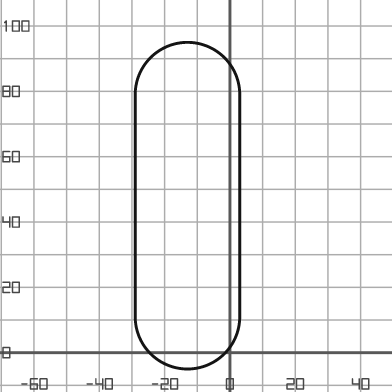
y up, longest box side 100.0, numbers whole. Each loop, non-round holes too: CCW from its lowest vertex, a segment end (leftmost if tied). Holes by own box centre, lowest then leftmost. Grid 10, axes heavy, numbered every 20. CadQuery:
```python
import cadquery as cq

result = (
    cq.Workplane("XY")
    .moveTo(-29.0, 11.0)
    .threePointArc((-13.0, -5.0), (3.0, 11.0))
    .lineTo(3.0, 79.0)
    .threePointArc((-13.0, 95.0), (-29.0, 79.0))
    .close()
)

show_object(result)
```